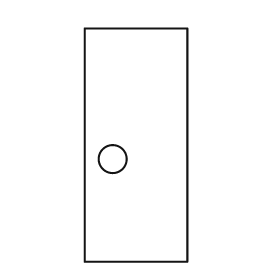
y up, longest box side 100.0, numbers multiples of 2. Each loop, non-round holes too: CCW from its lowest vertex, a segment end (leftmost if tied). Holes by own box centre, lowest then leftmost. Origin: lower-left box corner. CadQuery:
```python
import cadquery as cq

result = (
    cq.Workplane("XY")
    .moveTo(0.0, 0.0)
    .lineTo(44.0, 0.0)
    .lineTo(44.0, 100.0)
    .lineTo(0.0, 100.0)
    .close()
    .moveTo(12.0, 44.0)
    .circle(6.0)
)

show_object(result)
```